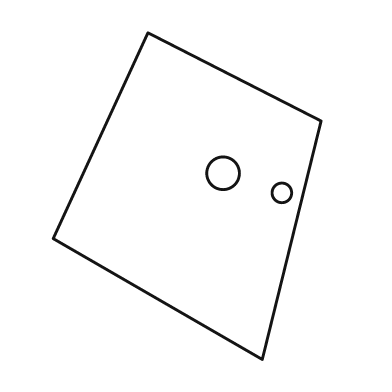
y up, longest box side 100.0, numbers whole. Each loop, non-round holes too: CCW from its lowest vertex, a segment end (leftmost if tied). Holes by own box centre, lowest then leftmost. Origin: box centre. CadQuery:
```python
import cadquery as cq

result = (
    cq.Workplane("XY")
    .moveTo(23.0, -50.0)
    .lineTo(41.0, 23.0)
    .lineTo(-12.0, 50.0)
    .lineTo(-41.0, -13.0)
    .close()
    .moveTo(29.0, 1.0)
    .circle(3.0)
    .moveTo(11.0, 7.0)
    .circle(5.0)
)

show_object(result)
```